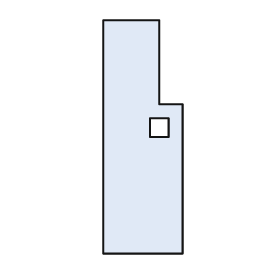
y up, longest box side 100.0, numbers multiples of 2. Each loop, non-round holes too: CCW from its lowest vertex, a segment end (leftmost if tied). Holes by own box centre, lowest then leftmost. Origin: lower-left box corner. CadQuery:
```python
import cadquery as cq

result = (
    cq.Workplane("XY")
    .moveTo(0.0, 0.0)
    .lineTo(34.0, 0.0)
    .lineTo(34.0, 64.0)
    .lineTo(24.0, 64.0)
    .lineTo(24.0, 100.0)
    .lineTo(0.0, 100.0)
    .close()
    .moveTo(20.0, 50.0)
    .lineTo(28.0, 50.0)
    .lineTo(28.0, 58.0)
    .lineTo(20.0, 58.0)
    .close()
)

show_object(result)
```